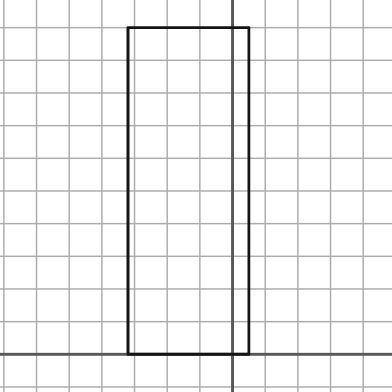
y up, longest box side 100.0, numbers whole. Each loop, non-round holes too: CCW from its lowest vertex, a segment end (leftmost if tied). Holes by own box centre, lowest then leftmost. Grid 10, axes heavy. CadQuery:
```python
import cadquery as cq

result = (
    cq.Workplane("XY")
    .moveTo(-32.0, 0.0)
    .lineTo(5.0, 0.0)
    .lineTo(5.0, 100.0)
    .lineTo(-32.0, 100.0)
    .close()
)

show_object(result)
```